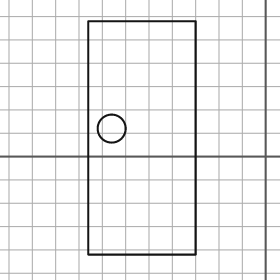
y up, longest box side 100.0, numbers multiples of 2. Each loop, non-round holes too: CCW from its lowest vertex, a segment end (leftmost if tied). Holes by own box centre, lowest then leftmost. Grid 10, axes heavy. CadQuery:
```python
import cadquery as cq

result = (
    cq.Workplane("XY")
    .moveTo(-76.0, -42.0)
    .lineTo(-30.0, -42.0)
    .lineTo(-30.0, 58.0)
    .lineTo(-76.0, 58.0)
    .close()
    .moveTo(-66.0, 12.0)
    .circle(6.0)
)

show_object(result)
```